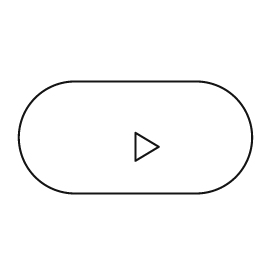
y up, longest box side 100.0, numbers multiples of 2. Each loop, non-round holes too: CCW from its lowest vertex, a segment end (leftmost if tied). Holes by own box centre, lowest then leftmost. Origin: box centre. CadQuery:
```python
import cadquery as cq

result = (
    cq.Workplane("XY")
    .moveTo(-26.0, -24.0)
    .lineTo(26.0, -24.0)
    .threePointArc((50.0, 0.0), (26.0, 24.0))
    .lineTo(-26.0, 24.0)
    .threePointArc((-50.0, 0.0), (-26.0, -24.0))
    .close()
    .moveTo(0.0, -10.0)
    .lineTo(10.0, -4.0)
    .lineTo(0.0, 2.0)
    .close()
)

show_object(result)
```